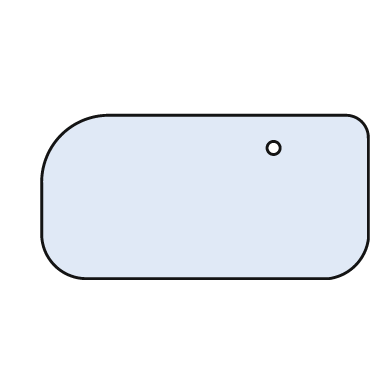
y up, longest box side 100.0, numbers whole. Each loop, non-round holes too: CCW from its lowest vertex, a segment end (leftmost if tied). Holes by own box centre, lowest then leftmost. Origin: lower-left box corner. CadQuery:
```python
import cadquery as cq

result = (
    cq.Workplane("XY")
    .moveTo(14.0, 0.0)
    .lineTo(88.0, 0.0)
    .threePointArc((96.0, 4.0), (100.0, 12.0))
    .lineTo(100.0, 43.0)
    .threePointArc((98.0, 48.0), (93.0, 50.0))
    .lineTo(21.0, 50.0)
    .threePointArc((6.0, 44.0), (0.0, 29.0))
    .lineTo(0.0, 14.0)
    .threePointArc((4.0, 4.0), (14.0, 0.0))
    .close()
    .moveTo(71.0, 40.0)
    .circle(2.0)
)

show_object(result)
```